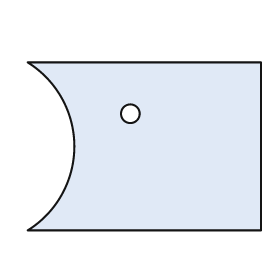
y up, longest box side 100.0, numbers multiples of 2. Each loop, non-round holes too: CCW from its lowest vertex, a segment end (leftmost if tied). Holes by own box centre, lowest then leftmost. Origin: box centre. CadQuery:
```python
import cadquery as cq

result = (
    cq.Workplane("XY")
    .moveTo(-50.0, -36.0)
    .lineTo(50.0, -36.0)
    .lineTo(50.0, 36.0)
    .lineTo(-50.0, 36.0)
    .threePointArc((-30.0, 0.0), (-50.0, -36.0))
    .close()
    .moveTo(-6.0, 14.0)
    .circle(4.0)
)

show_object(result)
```